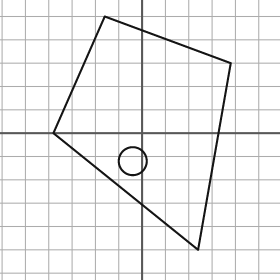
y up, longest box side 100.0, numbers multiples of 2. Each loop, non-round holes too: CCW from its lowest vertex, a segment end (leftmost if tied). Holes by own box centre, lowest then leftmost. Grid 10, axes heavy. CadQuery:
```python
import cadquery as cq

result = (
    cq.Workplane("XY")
    .moveTo(24.0, -50.0)
    .lineTo(38.0, 30.0)
    .lineTo(-16.0, 50.0)
    .lineTo(-38.0, 0.0)
    .close()
    .moveTo(-4.0, -12.0)
    .circle(6.0)
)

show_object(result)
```